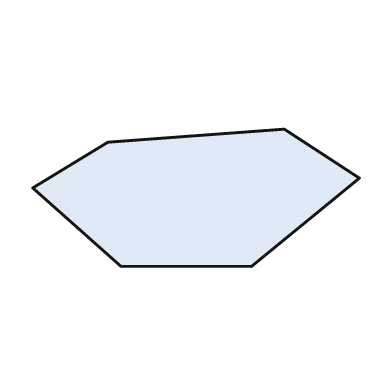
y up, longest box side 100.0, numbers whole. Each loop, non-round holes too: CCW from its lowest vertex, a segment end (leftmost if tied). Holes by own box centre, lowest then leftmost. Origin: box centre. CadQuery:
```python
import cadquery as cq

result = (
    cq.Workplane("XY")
    .moveTo(-23.0, -21.0)
    .lineTo(17.0, -21.0)
    .lineTo(50.0, 6.0)
    .lineTo(27.0, 21.0)
    .lineTo(-27.0, 17.0)
    .lineTo(-50.0, 3.0)
    .close()
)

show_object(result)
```